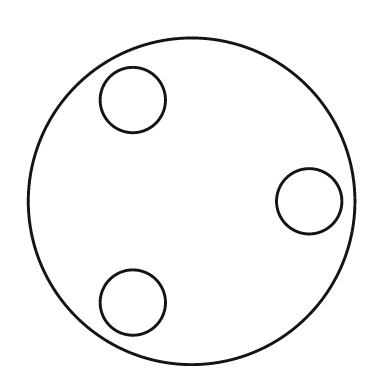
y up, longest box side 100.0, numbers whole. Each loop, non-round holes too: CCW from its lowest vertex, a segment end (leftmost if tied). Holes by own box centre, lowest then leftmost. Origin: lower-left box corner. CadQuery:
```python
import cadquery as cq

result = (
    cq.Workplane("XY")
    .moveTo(50.0, 50.0)
    .circle(50.0)
    .moveTo(32.0, 19.0)
    .circle(10.0)
    .moveTo(86.0, 50.0)
    .circle(10.0)
    .moveTo(32.0, 81.0)
    .circle(10.0)
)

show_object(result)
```